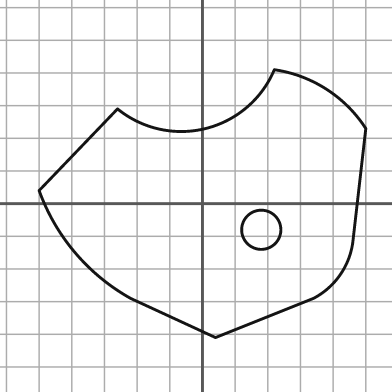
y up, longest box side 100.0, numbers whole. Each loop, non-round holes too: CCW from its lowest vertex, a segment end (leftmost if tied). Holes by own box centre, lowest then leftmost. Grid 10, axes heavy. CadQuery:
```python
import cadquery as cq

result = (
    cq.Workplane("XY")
    .moveTo(4.0, -41.0)
    .lineTo(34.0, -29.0)
    .threePointArc((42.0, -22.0), (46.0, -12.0))
    .lineTo(50.0, 23.0)
    .threePointArc((38.0, 35.0), (22.0, 41.0))
    .threePointArc((1.0, 23.0), (-26.0, 29.0))
    .lineTo(-50.0, 4.0)
    .threePointArc((-39.0, -15.0), (-22.0, -29.0))
    .close()
    .moveTo(18.0, -8.0)
    .circle(6.0)
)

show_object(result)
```